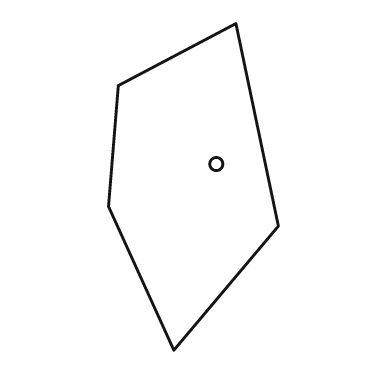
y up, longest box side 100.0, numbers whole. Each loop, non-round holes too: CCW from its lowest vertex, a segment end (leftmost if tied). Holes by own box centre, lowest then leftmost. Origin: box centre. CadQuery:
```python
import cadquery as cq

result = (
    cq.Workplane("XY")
    .moveTo(-6.0, -50.0)
    .lineTo(26.0, -12.0)
    .lineTo(13.0, 50.0)
    .lineTo(-23.0, 31.0)
    .lineTo(-26.0, -6.0)
    .close()
    .moveTo(7.0, 7.0)
    .circle(2.0)
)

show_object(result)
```